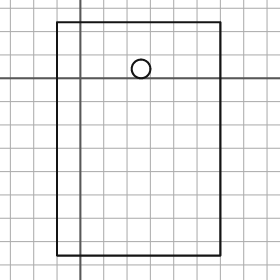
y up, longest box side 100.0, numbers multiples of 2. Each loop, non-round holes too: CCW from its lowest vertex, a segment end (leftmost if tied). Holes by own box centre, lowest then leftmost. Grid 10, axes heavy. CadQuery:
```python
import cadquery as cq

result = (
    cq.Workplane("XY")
    .moveTo(-10.0, -76.0)
    .lineTo(60.0, -76.0)
    .lineTo(60.0, 24.0)
    .lineTo(-10.0, 24.0)
    .close()
    .moveTo(26.0, 4.0)
    .circle(4.0)
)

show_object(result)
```